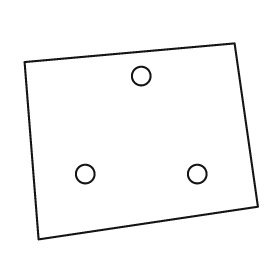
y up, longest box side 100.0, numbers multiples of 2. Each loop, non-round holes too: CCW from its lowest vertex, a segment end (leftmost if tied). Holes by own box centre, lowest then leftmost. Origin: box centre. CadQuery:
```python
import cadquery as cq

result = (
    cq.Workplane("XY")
    .moveTo(-44.0, -42.0)
    .lineTo(50.0, -28.0)
    .lineTo(40.0, 42.0)
    .lineTo(-50.0, 34.0)
    .close()
    .moveTo(-24.0, -14.0)
    .circle(4.0)
    .moveTo(24.0, -14.0)
    .circle(4.0)
    .moveTo(0.0, 28.0)
    .circle(4.0)
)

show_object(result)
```